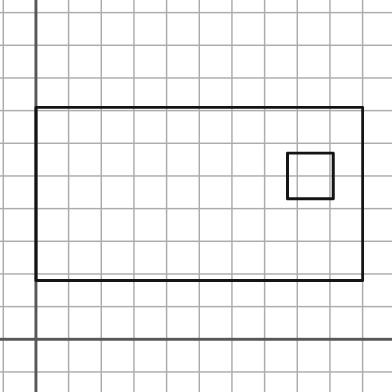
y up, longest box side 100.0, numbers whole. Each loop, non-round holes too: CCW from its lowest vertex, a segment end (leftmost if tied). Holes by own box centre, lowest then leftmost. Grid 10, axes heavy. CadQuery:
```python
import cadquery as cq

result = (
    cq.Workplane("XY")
    .moveTo(0.0, 18.0)
    .lineTo(100.0, 18.0)
    .lineTo(100.0, 71.0)
    .lineTo(0.0, 71.0)
    .close()
    .moveTo(77.0, 43.0)
    .lineTo(91.0, 43.0)
    .lineTo(91.0, 57.0)
    .lineTo(77.0, 57.0)
    .close()
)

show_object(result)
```